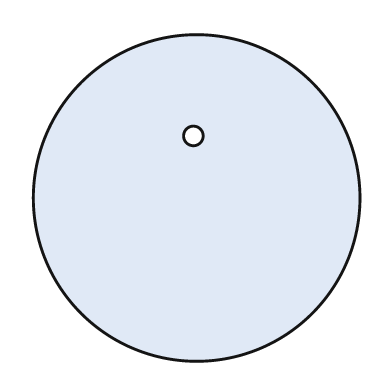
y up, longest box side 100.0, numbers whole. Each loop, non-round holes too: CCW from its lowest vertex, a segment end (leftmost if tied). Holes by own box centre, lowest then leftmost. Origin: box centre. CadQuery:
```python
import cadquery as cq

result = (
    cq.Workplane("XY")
    .moveTo(0.0, 0.0)
    .circle(50.0)
    .moveTo(-1.0, 19.0)
    .circle(3.0)
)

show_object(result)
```